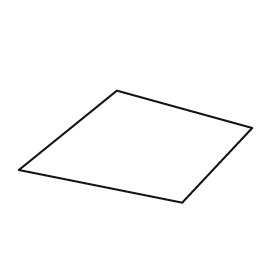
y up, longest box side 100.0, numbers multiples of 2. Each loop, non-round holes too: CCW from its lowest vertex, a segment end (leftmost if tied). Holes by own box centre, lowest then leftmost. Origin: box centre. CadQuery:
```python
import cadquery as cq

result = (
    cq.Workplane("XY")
    .moveTo(20.0, -24.0)
    .lineTo(50.0, 8.0)
    .lineTo(-8.0, 24.0)
    .lineTo(-50.0, -10.0)
    .close()
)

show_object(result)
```